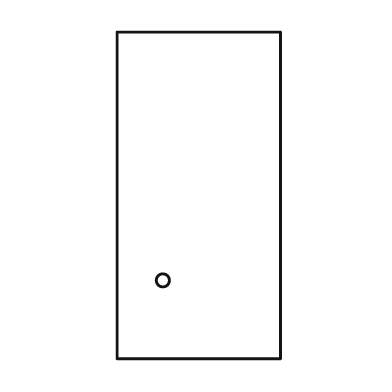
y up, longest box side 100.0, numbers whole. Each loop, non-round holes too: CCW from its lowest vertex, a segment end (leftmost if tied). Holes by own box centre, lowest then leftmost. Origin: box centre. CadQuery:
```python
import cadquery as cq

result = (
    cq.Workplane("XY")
    .moveTo(-25.0, -50.0)
    .lineTo(25.0, -50.0)
    .lineTo(25.0, 50.0)
    .lineTo(-25.0, 50.0)
    .close()
    .moveTo(-11.0, -26.0)
    .circle(2.0)
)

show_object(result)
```